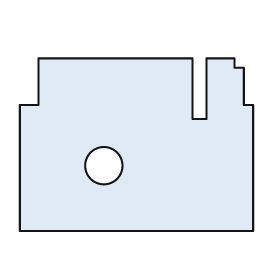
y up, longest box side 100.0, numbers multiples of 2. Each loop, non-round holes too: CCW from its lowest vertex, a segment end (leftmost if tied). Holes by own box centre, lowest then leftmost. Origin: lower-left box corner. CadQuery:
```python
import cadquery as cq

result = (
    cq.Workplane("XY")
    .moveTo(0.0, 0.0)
    .lineTo(100.0, 0.0)
    .lineTo(100.0, 54.0)
    .lineTo(96.0, 54.0)
    .lineTo(96.0, 70.0)
    .lineTo(92.0, 70.0)
    .lineTo(92.0, 74.0)
    .lineTo(80.0, 74.0)
    .lineTo(80.0, 48.0)
    .lineTo(74.0, 48.0)
    .lineTo(74.0, 74.0)
    .lineTo(8.0, 74.0)
    .lineTo(8.0, 54.0)
    .lineTo(0.0, 54.0)
    .close()
    .moveTo(36.0, 28.0)
    .circle(8.0)
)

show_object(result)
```